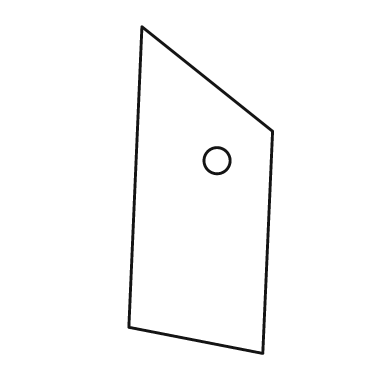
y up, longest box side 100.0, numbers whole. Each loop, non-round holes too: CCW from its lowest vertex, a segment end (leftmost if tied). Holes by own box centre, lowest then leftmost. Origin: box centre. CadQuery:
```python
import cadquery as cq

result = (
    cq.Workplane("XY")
    .moveTo(19.0, -50.0)
    .lineTo(22.0, 18.0)
    .lineTo(-18.0, 50.0)
    .lineTo(-22.0, -42.0)
    .close()
    .moveTo(5.0, 9.0)
    .circle(4.0)
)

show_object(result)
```